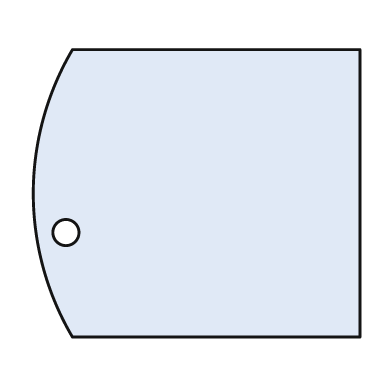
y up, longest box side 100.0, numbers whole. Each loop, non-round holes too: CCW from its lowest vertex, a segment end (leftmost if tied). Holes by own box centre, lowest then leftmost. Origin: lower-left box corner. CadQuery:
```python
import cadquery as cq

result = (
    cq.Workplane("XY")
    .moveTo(12.0, 0.0)
    .lineTo(100.0, 0.0)
    .lineTo(100.0, 88.0)
    .lineTo(12.0, 88.0)
    .threePointArc((0.0, 44.0), (12.0, 0.0))
    .close()
    .moveTo(10.0, 32.0)
    .circle(4.0)
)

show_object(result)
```